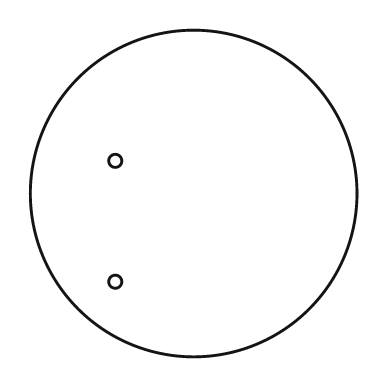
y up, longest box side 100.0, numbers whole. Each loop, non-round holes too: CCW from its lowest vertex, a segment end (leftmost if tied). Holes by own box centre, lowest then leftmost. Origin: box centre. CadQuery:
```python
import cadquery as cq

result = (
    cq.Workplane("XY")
    .moveTo(0.0, 0.0)
    .circle(50.0)
    .moveTo(-24.0, -27.0)
    .circle(2.0)
    .moveTo(-24.0, 10.0)
    .circle(2.0)
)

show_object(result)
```